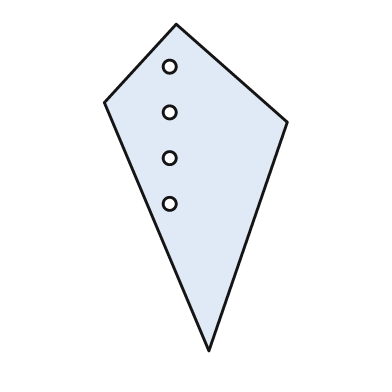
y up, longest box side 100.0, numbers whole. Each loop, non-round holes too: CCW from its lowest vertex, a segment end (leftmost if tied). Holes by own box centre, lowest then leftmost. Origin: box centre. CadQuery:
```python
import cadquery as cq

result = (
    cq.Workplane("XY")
    .moveTo(4.0, -50.0)
    .lineTo(28.0, 20.0)
    .lineTo(-6.0, 50.0)
    .lineTo(-28.0, 26.0)
    .close()
    .moveTo(-8.0, -5.0)
    .circle(2.0)
    .moveTo(-8.0, 9.0)
    .circle(2.0)
    .moveTo(-8.0, 23.0)
    .circle(2.0)
    .moveTo(-8.0, 37.0)
    .circle(2.0)
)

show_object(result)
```